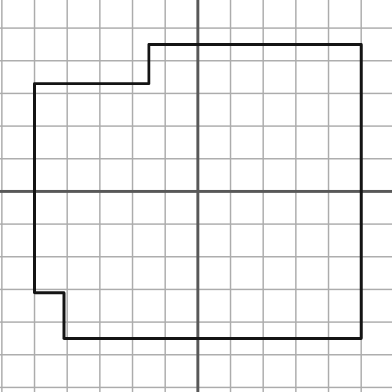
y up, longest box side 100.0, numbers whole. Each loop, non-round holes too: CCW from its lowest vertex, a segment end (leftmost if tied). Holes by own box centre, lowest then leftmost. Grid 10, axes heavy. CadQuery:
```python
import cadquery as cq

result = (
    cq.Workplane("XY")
    .moveTo(-41.0, -45.0)
    .lineTo(50.0, -45.0)
    .lineTo(50.0, 45.0)
    .lineTo(-15.0, 45.0)
    .lineTo(-15.0, 33.0)
    .lineTo(-50.0, 33.0)
    .lineTo(-50.0, -31.0)
    .lineTo(-41.0, -31.0)
    .close()
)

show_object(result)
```